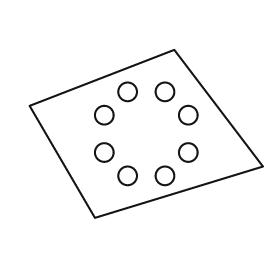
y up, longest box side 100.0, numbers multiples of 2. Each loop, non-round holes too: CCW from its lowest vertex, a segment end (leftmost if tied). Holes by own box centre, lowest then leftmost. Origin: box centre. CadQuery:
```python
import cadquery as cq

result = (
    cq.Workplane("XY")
    .moveTo(-22.0, -36.0)
    .lineTo(50.0, -14.0)
    .lineTo(12.0, 36.0)
    .lineTo(-50.0, 12.0)
    .close()
    .moveTo(-8.0, -18.0)
    .circle(4.0)
    .moveTo(8.0, -18.0)
    .circle(4.0)
    .moveTo(-18.0, -8.0)
    .circle(4.0)
    .moveTo(18.0, -8.0)
    .circle(4.0)
    .moveTo(-18.0, 8.0)
    .circle(4.0)
    .moveTo(18.0, 8.0)
    .circle(4.0)
    .moveTo(-8.0, 18.0)
    .circle(4.0)
    .moveTo(8.0, 18.0)
    .circle(4.0)
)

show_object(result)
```